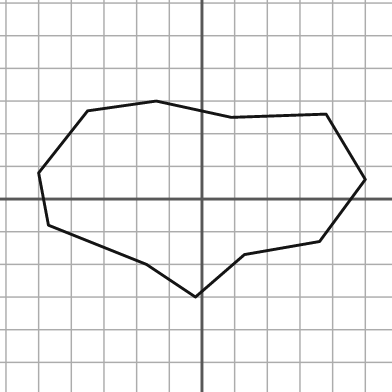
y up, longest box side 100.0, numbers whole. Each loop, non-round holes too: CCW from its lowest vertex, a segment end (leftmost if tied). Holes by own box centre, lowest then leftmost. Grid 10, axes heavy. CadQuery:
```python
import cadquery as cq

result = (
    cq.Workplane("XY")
    .moveTo(-2.0, -30.0)
    .lineTo(13.0, -17.0)
    .lineTo(36.0, -13.0)
    .lineTo(50.0, 6.0)
    .lineTo(38.0, 26.0)
    .lineTo(9.0, 25.0)
    .lineTo(-14.0, 30.0)
    .lineTo(-35.0, 27.0)
    .lineTo(-50.0, 8.0)
    .lineTo(-47.0, -8.0)
    .lineTo(-17.0, -20.0)
    .close()
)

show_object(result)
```